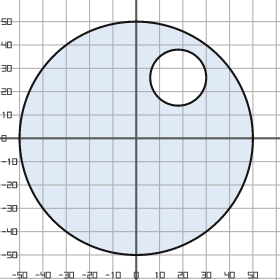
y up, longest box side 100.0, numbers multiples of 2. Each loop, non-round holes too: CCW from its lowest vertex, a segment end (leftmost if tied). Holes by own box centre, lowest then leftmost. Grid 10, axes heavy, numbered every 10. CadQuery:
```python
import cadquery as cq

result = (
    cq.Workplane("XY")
    .moveTo(0.0, 0.0)
    .circle(50.0)
    .moveTo(18.0, 26.0)
    .circle(12.0)
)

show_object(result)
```